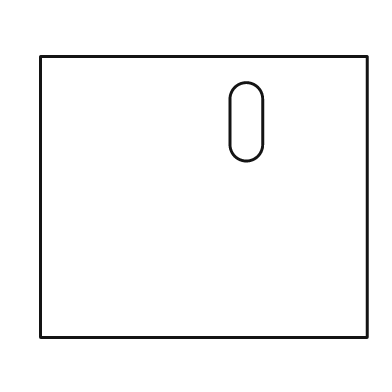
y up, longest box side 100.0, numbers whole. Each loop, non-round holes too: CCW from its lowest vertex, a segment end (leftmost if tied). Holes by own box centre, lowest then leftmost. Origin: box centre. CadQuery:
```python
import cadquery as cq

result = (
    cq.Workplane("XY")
    .moveTo(-50.0, -43.0)
    .lineTo(50.0, -43.0)
    .lineTo(50.0, 43.0)
    .lineTo(-50.0, 43.0)
    .close()
    .moveTo(8.0, 16.0)
    .threePointArc((13.0, 11.0), (18.0, 16.0))
    .lineTo(18.0, 30.0)
    .threePointArc((13.0, 35.0), (8.0, 30.0))
    .close()
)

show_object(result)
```